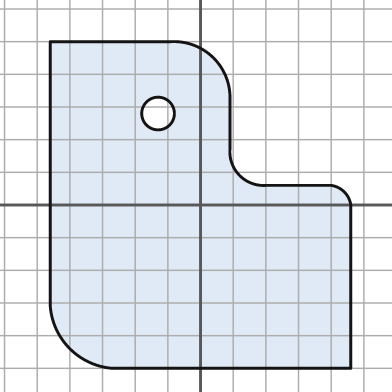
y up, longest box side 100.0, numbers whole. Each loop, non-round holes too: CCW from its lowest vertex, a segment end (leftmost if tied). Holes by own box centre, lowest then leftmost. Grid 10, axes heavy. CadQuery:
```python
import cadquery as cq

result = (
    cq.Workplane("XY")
    .moveTo(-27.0, -50.0)
    .lineTo(46.0, -50.0)
    .lineTo(46.0, 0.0)
    .threePointArc((44.0, 4.0), (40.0, 6.0))
    .lineTo(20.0, 6.0)
    .threePointArc((12.0, 9.0), (9.0, 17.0))
    .lineTo(9.0, 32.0)
    .threePointArc((4.0, 45.0), (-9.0, 50.0))
    .lineTo(-46.0, 50.0)
    .lineTo(-46.0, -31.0)
    .threePointArc((-40.0, -44.0), (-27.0, -50.0))
    .close()
    .moveTo(-13.0, 28.0)
    .circle(5.0)
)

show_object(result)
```